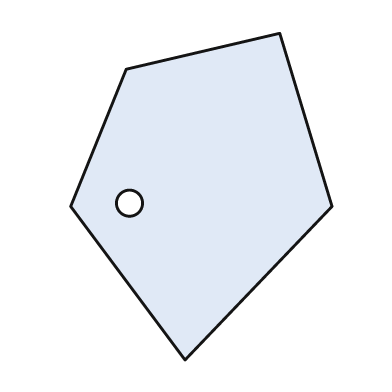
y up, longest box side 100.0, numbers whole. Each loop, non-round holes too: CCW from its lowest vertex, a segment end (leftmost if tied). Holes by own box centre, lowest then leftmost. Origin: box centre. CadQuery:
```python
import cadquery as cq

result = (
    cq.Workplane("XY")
    .moveTo(-5.0, -50.0)
    .lineTo(40.0, -3.0)
    .lineTo(24.0, 50.0)
    .lineTo(-23.0, 39.0)
    .lineTo(-40.0, -3.0)
    .close()
    .moveTo(-22.0, -2.0)
    .circle(4.0)
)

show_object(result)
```